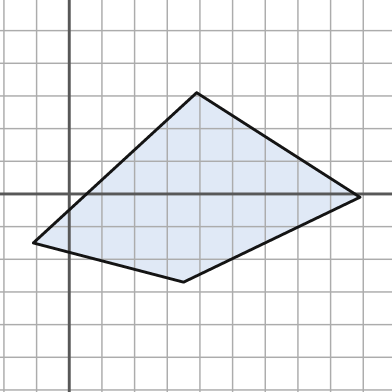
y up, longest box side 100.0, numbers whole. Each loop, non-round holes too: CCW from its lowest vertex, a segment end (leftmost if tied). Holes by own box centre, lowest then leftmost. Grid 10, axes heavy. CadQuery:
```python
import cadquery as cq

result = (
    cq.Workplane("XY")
    .moveTo(35.0, -27.0)
    .lineTo(89.0, -1.0)
    .lineTo(39.0, 31.0)
    .lineTo(-11.0, -15.0)
    .close()
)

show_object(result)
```